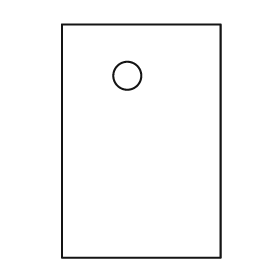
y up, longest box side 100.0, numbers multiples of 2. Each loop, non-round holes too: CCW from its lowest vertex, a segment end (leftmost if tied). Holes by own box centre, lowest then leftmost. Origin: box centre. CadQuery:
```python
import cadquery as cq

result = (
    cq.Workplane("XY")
    .moveTo(-34.0, -50.0)
    .lineTo(34.0, -50.0)
    .lineTo(34.0, 50.0)
    .lineTo(-34.0, 50.0)
    .close()
    .moveTo(-6.0, 28.0)
    .circle(6.0)
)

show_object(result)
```